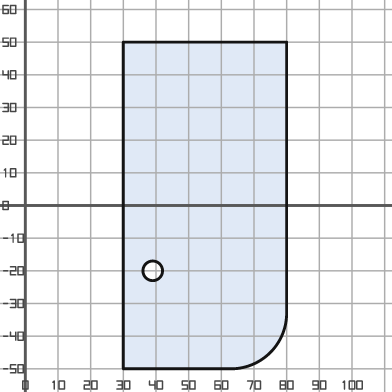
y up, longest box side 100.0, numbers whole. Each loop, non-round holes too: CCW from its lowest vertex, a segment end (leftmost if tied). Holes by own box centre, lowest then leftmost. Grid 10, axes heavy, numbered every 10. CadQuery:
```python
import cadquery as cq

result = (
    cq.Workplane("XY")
    .moveTo(30.0, -50.0)
    .lineTo(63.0, -50.0)
    .threePointArc((75.0, -45.0), (80.0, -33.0))
    .lineTo(80.0, 50.0)
    .lineTo(30.0, 50.0)
    .close()
    .moveTo(39.0, -20.0)
    .circle(3.0)
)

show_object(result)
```